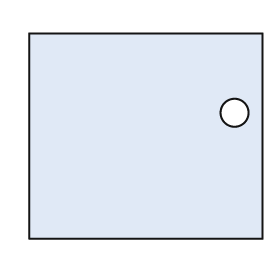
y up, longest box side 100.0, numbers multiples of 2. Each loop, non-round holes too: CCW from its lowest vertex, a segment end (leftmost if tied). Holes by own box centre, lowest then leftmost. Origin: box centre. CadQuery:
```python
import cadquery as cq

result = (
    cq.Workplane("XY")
    .moveTo(-50.0, -44.0)
    .lineTo(50.0, -44.0)
    .lineTo(50.0, 44.0)
    .lineTo(-50.0, 44.0)
    .close()
    .moveTo(38.0, 10.0)
    .circle(6.0)
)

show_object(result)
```